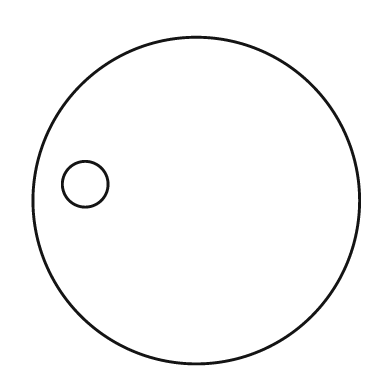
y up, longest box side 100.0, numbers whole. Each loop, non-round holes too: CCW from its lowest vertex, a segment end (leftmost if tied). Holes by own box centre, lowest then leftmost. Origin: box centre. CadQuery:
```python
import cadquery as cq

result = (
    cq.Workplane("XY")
    .moveTo(0.0, 0.0)
    .circle(50.0)
    .moveTo(-34.0, 5.0)
    .circle(7.0)
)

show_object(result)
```